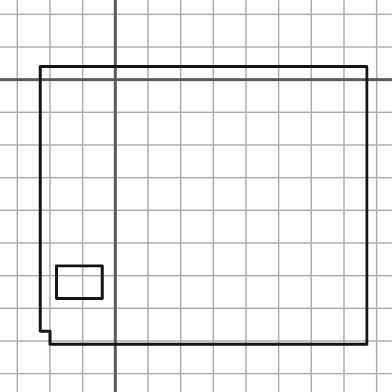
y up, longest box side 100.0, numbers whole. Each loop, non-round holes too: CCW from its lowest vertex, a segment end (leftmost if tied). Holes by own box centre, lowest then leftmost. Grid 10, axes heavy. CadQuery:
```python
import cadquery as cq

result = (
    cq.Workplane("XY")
    .moveTo(-20.0, -81.0)
    .lineTo(77.0, -81.0)
    .lineTo(77.0, 4.0)
    .lineTo(-23.0, 4.0)
    .lineTo(-23.0, -77.0)
    .lineTo(-20.0, -77.0)
    .close()
    .moveTo(-18.0, -67.0)
    .lineTo(-4.0, -67.0)
    .lineTo(-4.0, -57.0)
    .lineTo(-18.0, -57.0)
    .close()
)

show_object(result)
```